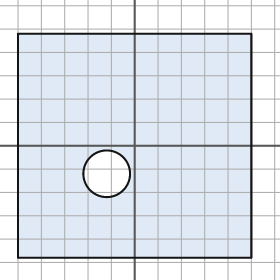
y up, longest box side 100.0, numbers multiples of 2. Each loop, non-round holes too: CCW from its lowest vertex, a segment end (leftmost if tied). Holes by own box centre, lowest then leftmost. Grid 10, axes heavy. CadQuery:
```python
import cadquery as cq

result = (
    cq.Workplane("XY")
    .moveTo(-50.0, -48.0)
    .lineTo(50.0, -48.0)
    .lineTo(50.0, 48.0)
    .lineTo(-50.0, 48.0)
    .close()
    .moveTo(-12.0, -12.0)
    .circle(10.0)
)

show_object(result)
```